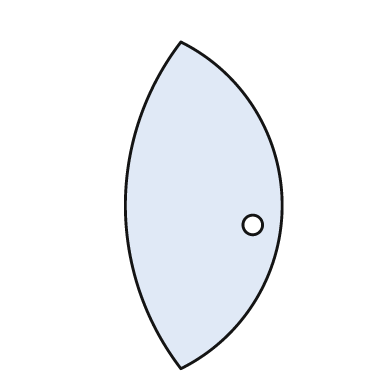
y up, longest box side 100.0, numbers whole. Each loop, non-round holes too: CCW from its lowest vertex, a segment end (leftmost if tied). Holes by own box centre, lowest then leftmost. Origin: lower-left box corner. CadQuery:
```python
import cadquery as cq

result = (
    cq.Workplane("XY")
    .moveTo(17.0, 0.0)
    .threePointArc((48.0, 50.0), (17.0, 100.0))
    .threePointArc((0.0, 50.0), (17.0, 0.0))
    .close()
    .moveTo(39.0, 44.0)
    .circle(3.0)
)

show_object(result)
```